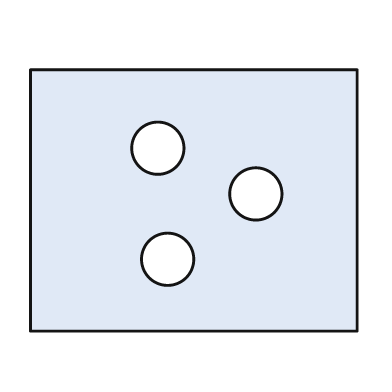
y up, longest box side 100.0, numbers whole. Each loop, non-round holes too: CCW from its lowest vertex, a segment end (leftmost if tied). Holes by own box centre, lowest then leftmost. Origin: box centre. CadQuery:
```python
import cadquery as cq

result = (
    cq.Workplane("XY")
    .moveTo(-50.0, -40.0)
    .lineTo(50.0, -40.0)
    .lineTo(50.0, 40.0)
    .lineTo(-50.0, 40.0)
    .close()
    .moveTo(-8.0, -18.0)
    .circle(8.0)
    .moveTo(19.0, 2.0)
    .circle(8.0)
    .moveTo(-11.0, 16.0)
    .circle(8.0)
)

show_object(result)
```